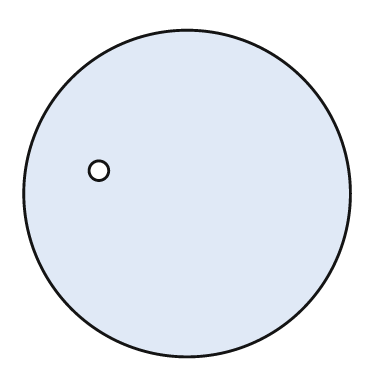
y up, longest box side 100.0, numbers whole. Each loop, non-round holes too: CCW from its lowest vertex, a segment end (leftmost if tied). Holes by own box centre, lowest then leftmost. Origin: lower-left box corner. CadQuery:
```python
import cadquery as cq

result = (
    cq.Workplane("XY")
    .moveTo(50.0, 50.0)
    .circle(50.0)
    .moveTo(23.0, 57.0)
    .circle(3.0)
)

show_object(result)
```